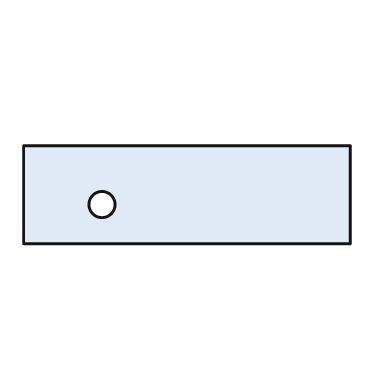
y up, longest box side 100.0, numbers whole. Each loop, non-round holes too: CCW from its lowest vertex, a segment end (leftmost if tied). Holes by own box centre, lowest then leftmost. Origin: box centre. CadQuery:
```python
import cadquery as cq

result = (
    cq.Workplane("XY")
    .moveTo(-50.0, -15.0)
    .lineTo(50.0, -15.0)
    .lineTo(50.0, 15.0)
    .lineTo(-50.0, 15.0)
    .close()
    .moveTo(-26.0, -3.0)
    .circle(4.0)
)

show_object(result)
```